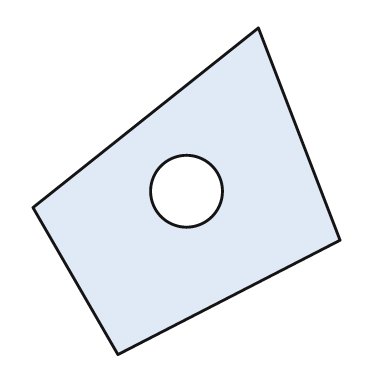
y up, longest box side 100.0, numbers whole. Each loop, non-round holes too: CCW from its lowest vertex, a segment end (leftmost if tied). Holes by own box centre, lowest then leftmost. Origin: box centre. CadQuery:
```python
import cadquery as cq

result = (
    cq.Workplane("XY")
    .moveTo(-21.0, -50.0)
    .lineTo(47.0, -15.0)
    .lineTo(22.0, 50.0)
    .lineTo(-47.0, -5.0)
    .close()
    .moveTo(0.0, 0.0)
    .circle(11.0)
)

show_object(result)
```